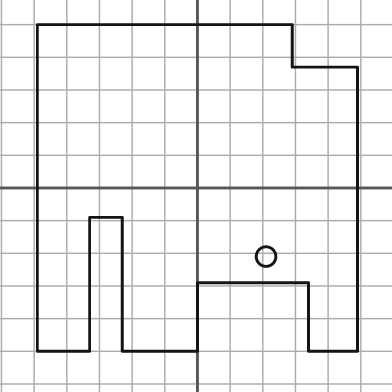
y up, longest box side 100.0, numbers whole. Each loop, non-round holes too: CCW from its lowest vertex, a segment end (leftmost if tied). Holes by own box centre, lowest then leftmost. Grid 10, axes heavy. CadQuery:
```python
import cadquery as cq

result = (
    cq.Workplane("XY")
    .moveTo(-49.0, -50.0)
    .lineTo(-33.0, -50.0)
    .lineTo(-33.0, -9.0)
    .lineTo(-23.0, -9.0)
    .lineTo(-23.0, -50.0)
    .lineTo(0.0, -50.0)
    .lineTo(0.0, -29.0)
    .lineTo(34.0, -29.0)
    .lineTo(34.0, -50.0)
    .lineTo(49.0, -50.0)
    .lineTo(49.0, 37.0)
    .lineTo(29.0, 37.0)
    .lineTo(29.0, 50.0)
    .lineTo(-49.0, 50.0)
    .close()
    .moveTo(21.0, -21.0)
    .circle(3.0)
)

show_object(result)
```